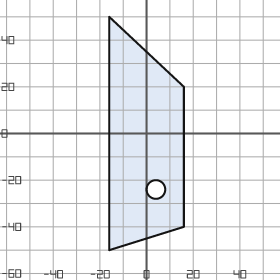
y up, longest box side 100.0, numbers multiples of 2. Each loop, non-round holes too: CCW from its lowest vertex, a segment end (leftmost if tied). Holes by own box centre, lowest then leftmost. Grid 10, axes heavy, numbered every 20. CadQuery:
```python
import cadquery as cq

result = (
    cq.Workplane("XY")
    .moveTo(-16.0, -50.0)
    .lineTo(16.0, -40.0)
    .lineTo(16.0, 20.0)
    .lineTo(-16.0, 50.0)
    .close()
    .moveTo(4.0, -24.0)
    .circle(4.0)
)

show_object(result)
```